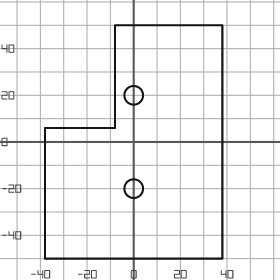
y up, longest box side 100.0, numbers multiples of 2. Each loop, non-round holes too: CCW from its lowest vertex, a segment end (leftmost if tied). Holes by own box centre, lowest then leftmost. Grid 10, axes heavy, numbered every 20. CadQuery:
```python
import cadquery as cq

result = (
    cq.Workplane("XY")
    .moveTo(-38.0, -50.0)
    .lineTo(38.0, -50.0)
    .lineTo(38.0, 50.0)
    .lineTo(-8.0, 50.0)
    .lineTo(-8.0, 6.0)
    .lineTo(-38.0, 6.0)
    .close()
    .moveTo(0.0, -20.0)
    .circle(4.0)
    .moveTo(0.0, 20.0)
    .circle(4.0)
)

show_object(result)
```